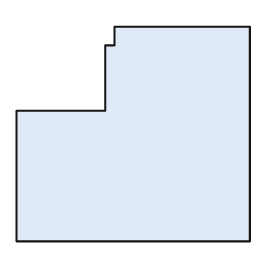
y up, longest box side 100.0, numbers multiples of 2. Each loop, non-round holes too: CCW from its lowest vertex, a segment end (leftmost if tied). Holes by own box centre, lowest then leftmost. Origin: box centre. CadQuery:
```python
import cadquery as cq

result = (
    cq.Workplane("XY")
    .moveTo(-50.0, -46.0)
    .lineTo(50.0, -46.0)
    .lineTo(50.0, 46.0)
    .lineTo(-8.0, 46.0)
    .lineTo(-8.0, 38.0)
    .lineTo(-12.0, 38.0)
    .lineTo(-12.0, 10.0)
    .lineTo(-50.0, 10.0)
    .close()
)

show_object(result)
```